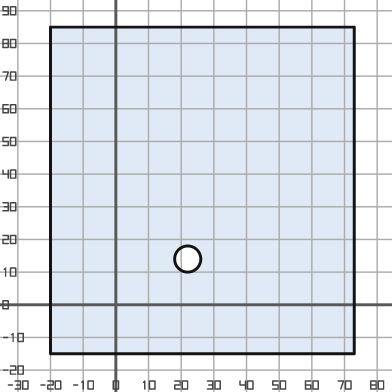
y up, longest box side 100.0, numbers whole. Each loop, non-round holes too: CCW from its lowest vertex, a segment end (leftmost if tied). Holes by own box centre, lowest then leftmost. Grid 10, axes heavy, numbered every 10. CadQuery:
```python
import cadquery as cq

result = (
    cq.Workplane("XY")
    .moveTo(-20.0, -15.0)
    .lineTo(73.0, -15.0)
    .lineTo(73.0, 85.0)
    .lineTo(-20.0, 85.0)
    .close()
    .moveTo(22.0, 14.0)
    .circle(4.0)
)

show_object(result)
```